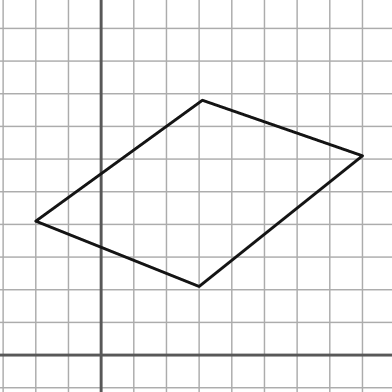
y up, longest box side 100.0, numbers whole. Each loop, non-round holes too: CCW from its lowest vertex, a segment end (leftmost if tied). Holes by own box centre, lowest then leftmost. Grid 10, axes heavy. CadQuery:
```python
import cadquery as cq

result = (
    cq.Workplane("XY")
    .moveTo(30.0, 21.0)
    .lineTo(80.0, 61.0)
    .lineTo(31.0, 78.0)
    .lineTo(-20.0, 41.0)
    .close()
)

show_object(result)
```